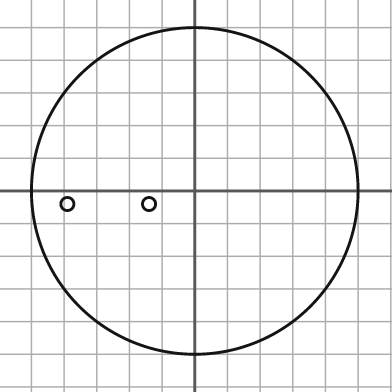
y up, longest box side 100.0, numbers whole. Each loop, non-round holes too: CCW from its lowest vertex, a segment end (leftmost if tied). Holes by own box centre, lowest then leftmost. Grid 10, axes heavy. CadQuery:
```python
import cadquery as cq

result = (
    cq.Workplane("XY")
    .moveTo(0.0, 0.0)
    .circle(50.0)
    .moveTo(-39.0, -4.0)
    .circle(2.0)
    .moveTo(-14.0, -4.0)
    .circle(2.0)
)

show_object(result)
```